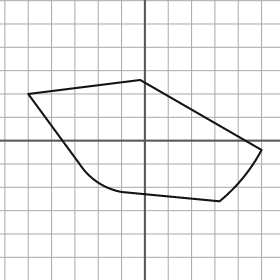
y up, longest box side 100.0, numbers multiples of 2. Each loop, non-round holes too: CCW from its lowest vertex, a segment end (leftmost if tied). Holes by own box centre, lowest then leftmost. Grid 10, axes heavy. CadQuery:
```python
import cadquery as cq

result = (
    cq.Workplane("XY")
    .moveTo(32.0, -26.0)
    .threePointArc((42.0, -16.0), (50.0, -4.0))
    .lineTo(-2.0, 26.0)
    .lineTo(-50.0, 20.0)
    .lineTo(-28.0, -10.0)
    .threePointArc((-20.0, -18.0), (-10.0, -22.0))
    .close()
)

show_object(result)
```